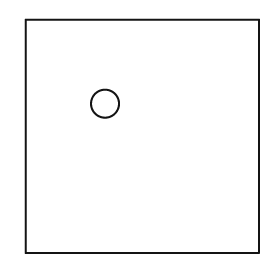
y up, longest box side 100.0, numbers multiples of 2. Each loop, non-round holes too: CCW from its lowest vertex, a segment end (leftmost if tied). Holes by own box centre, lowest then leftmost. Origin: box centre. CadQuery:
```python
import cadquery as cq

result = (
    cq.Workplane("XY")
    .moveTo(-50.0, -50.0)
    .lineTo(50.0, -50.0)
    .lineTo(50.0, 50.0)
    .lineTo(-50.0, 50.0)
    .close()
    .moveTo(-16.0, 14.0)
    .circle(6.0)
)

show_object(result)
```